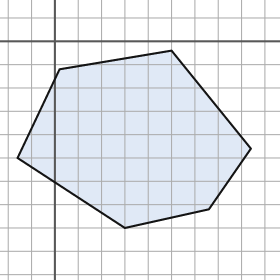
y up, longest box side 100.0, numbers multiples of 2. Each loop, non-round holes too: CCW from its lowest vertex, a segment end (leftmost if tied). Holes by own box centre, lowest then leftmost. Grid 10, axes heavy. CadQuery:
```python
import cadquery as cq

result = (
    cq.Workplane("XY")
    .moveTo(30.0, -80.0)
    .lineTo(66.0, -72.0)
    .lineTo(84.0, -46.0)
    .lineTo(50.0, -4.0)
    .lineTo(2.0, -12.0)
    .lineTo(-16.0, -50.0)
    .close()
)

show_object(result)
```